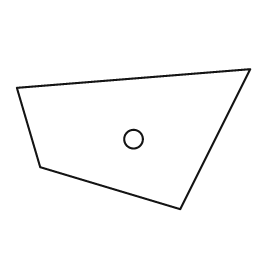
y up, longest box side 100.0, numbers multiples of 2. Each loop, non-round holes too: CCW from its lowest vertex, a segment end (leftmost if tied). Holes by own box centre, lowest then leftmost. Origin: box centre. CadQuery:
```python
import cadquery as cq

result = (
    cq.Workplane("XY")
    .moveTo(20.0, -30.0)
    .lineTo(50.0, 30.0)
    .lineTo(-50.0, 22.0)
    .lineTo(-40.0, -12.0)
    .close()
    .moveTo(0.0, 0.0)
    .circle(4.0)
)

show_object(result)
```